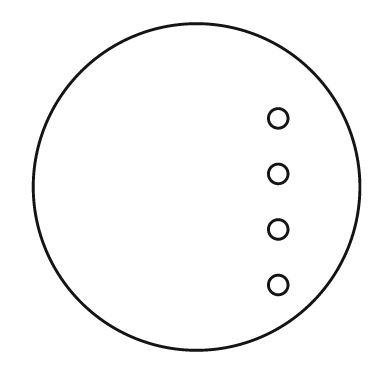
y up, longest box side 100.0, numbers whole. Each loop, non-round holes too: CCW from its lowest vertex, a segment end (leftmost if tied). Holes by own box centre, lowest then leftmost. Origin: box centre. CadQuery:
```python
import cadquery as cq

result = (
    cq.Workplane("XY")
    .moveTo(0.0, 0.0)
    .circle(50.0)
    .moveTo(25.0, -30.0)
    .circle(3.0)
    .moveTo(25.0, -13.0)
    .circle(3.0)
    .moveTo(25.0, 4.0)
    .circle(3.0)
    .moveTo(25.0, 21.0)
    .circle(3.0)
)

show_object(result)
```